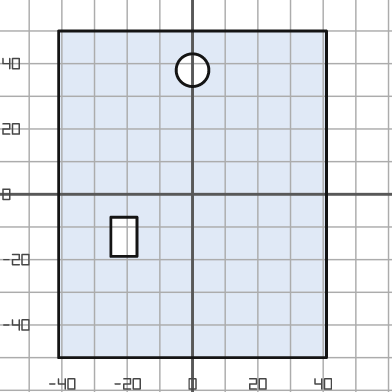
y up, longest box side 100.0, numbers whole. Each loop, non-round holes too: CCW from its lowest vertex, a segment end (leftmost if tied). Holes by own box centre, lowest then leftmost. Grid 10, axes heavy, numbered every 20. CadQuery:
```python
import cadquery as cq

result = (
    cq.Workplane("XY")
    .moveTo(-41.0, -50.0)
    .lineTo(41.0, -50.0)
    .lineTo(41.0, 50.0)
    .lineTo(-41.0, 50.0)
    .close()
    .moveTo(-25.0, -19.0)
    .lineTo(-17.0, -19.0)
    .lineTo(-17.0, -7.0)
    .lineTo(-25.0, -7.0)
    .close()
    .moveTo(0.0, 38.0)
    .circle(5.0)
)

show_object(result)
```